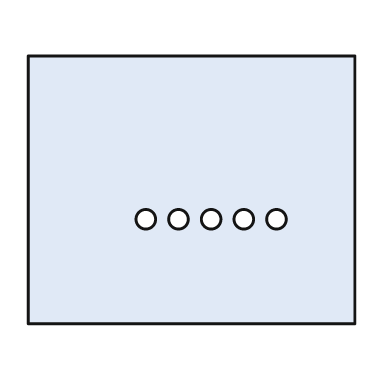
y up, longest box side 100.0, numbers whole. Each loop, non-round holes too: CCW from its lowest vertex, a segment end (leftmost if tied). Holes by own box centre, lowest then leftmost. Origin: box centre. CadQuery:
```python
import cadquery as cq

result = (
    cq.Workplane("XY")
    .moveTo(-50.0, -41.0)
    .lineTo(50.0, -41.0)
    .lineTo(50.0, 41.0)
    .lineTo(-50.0, 41.0)
    .close()
    .moveTo(-14.0, -9.0)
    .circle(3.0)
    .moveTo(-4.0, -9.0)
    .circle(3.0)
    .moveTo(6.0, -9.0)
    .circle(3.0)
    .moveTo(16.0, -9.0)
    .circle(3.0)
    .moveTo(26.0, -9.0)
    .circle(3.0)
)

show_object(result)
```